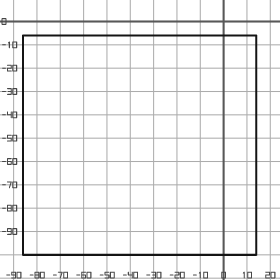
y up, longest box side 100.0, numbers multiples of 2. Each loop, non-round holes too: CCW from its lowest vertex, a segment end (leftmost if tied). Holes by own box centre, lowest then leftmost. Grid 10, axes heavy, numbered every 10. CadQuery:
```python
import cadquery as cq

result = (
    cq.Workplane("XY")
    .moveTo(-86.0, -100.0)
    .lineTo(14.0, -100.0)
    .lineTo(14.0, -6.0)
    .lineTo(-86.0, -6.0)
    .close()
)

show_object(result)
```